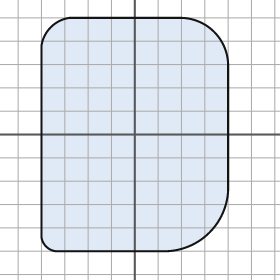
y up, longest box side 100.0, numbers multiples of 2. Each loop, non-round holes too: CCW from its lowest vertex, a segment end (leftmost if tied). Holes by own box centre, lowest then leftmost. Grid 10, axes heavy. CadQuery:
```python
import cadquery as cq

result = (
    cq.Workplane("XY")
    .moveTo(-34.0, -50.0)
    .lineTo(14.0, -50.0)
    .threePointArc((32.0, -42.0), (40.0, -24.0))
    .lineTo(40.0, 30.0)
    .threePointArc((34.0, 44.0), (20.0, 50.0))
    .lineTo(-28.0, 50.0)
    .threePointArc((-36.0, 46.0), (-40.0, 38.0))
    .lineTo(-40.0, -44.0)
    .threePointArc((-38.0, -48.0), (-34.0, -50.0))
    .close()
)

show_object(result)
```